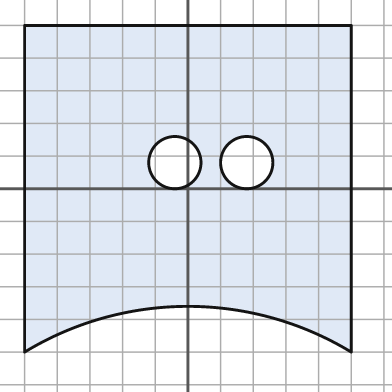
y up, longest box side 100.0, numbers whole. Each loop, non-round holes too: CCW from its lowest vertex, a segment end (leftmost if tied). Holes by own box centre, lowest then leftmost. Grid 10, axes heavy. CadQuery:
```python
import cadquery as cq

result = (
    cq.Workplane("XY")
    .moveTo(-50.0, -50.0)
    .threePointArc((0.0, -36.0), (50.0, -50.0))
    .lineTo(50.0, 50.0)
    .lineTo(-50.0, 50.0)
    .close()
    .moveTo(-4.0, 8.0)
    .circle(8.0)
    .moveTo(18.0, 8.0)
    .circle(8.0)
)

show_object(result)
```